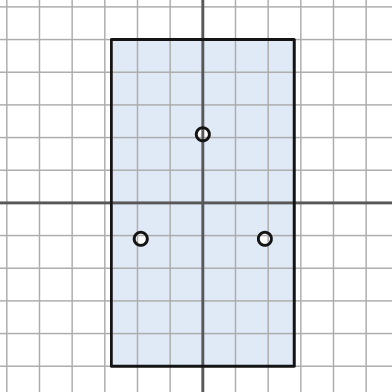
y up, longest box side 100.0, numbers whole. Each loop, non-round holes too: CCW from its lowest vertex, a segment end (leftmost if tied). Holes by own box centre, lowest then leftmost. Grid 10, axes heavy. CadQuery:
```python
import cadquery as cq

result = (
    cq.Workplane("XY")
    .moveTo(-28.0, -50.0)
    .lineTo(28.0, -50.0)
    .lineTo(28.0, 50.0)
    .lineTo(-28.0, 50.0)
    .close()
    .moveTo(-19.0, -11.0)
    .circle(2.0)
    .moveTo(19.0, -11.0)
    .circle(2.0)
    .moveTo(0.0, 21.0)
    .circle(2.0)
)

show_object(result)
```